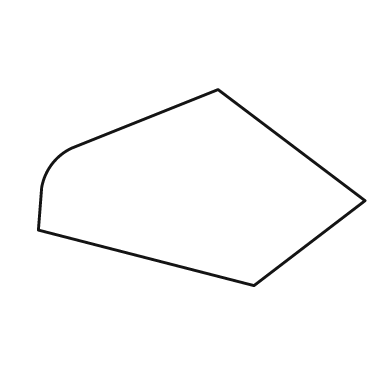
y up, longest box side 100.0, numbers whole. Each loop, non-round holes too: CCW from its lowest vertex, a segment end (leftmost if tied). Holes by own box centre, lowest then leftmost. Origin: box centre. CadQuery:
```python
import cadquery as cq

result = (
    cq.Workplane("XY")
    .moveTo(16.0, -30.0)
    .lineTo(50.0, -4.0)
    .lineTo(5.0, 30.0)
    .lineTo(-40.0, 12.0)
    .threePointArc((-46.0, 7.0), (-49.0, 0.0))
    .lineTo(-50.0, -13.0)
    .close()
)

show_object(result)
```